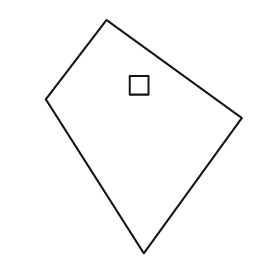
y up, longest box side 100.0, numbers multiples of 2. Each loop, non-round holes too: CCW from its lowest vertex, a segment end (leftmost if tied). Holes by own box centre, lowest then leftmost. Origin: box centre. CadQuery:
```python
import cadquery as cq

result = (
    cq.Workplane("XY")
    .moveTo(0.0, -50.0)
    .lineTo(42.0, 8.0)
    .lineTo(-16.0, 50.0)
    .lineTo(-42.0, 16.0)
    .close()
    .moveTo(-6.0, 18.0)
    .lineTo(2.0, 18.0)
    .lineTo(2.0, 26.0)
    .lineTo(-6.0, 26.0)
    .close()
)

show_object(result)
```